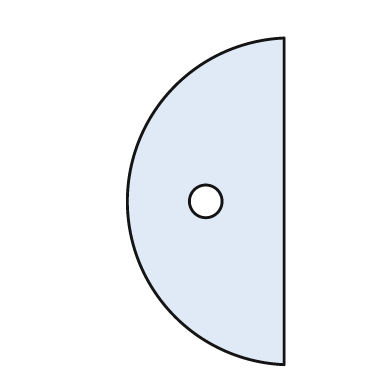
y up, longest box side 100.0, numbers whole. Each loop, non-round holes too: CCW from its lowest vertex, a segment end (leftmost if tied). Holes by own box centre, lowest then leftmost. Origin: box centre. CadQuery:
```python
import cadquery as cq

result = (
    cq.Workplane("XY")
    .moveTo(24.0, -50.0)
    .lineTo(24.0, 50.0)
    .threePointArc((-24.0, 0.0), (24.0, -50.0))
    .close()
    .moveTo(0.0, 0.0)
    .circle(5.0)
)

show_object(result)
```